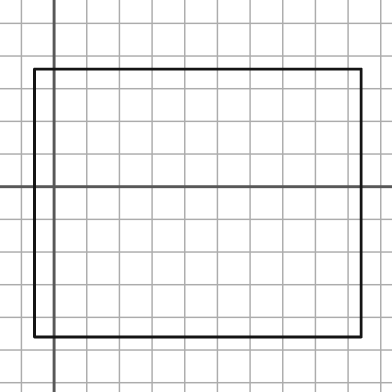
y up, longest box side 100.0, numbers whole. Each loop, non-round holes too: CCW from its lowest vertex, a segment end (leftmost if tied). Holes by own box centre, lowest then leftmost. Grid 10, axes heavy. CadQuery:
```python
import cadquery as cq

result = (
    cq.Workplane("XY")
    .moveTo(-6.0, -46.0)
    .lineTo(94.0, -46.0)
    .lineTo(94.0, 36.0)
    .lineTo(-6.0, 36.0)
    .close()
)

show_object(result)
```